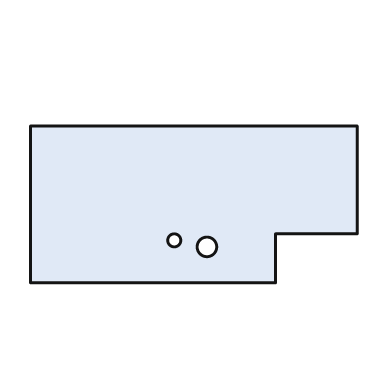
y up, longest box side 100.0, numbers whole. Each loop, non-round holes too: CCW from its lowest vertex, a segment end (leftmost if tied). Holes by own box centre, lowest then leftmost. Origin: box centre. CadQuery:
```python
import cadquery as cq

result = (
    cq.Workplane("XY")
    .moveTo(-50.0, -24.0)
    .lineTo(25.0, -24.0)
    .lineTo(25.0, -9.0)
    .lineTo(50.0, -9.0)
    .lineTo(50.0, 24.0)
    .lineTo(-50.0, 24.0)
    .close()
    .moveTo(4.0, -13.0)
    .circle(3.0)
    .moveTo(-6.0, -11.0)
    .circle(2.0)
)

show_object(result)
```